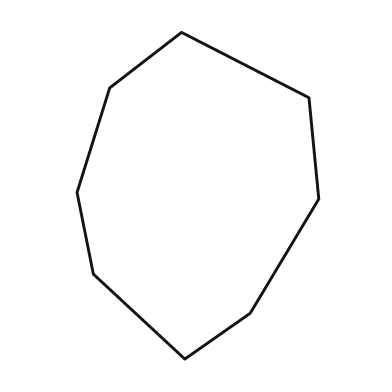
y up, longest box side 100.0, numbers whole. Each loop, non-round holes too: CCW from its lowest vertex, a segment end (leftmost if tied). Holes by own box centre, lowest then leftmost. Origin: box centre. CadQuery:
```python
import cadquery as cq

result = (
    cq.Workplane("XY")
    .moveTo(-4.0, -50.0)
    .lineTo(16.0, -36.0)
    .lineTo(37.0, -1.0)
    .lineTo(34.0, 30.0)
    .lineTo(-5.0, 50.0)
    .lineTo(-27.0, 33.0)
    .lineTo(-37.0, 1.0)
    .lineTo(-32.0, -24.0)
    .close()
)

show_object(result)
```